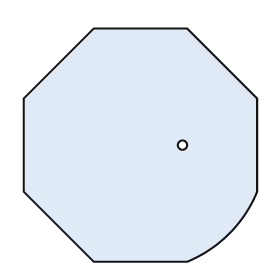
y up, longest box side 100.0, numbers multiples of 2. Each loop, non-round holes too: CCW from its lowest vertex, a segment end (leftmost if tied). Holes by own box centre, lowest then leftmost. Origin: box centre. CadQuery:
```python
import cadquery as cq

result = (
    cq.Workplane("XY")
    .moveTo(-20.0, -50.0)
    .lineTo(20.0, -50.0)
    .threePointArc((38.0, -38.0), (50.0, -20.0))
    .lineTo(50.0, 20.0)
    .lineTo(20.0, 50.0)
    .lineTo(-20.0, 50.0)
    .lineTo(-50.0, 20.0)
    .lineTo(-50.0, -20.0)
    .close()
    .moveTo(18.0, 0.0)
    .circle(2.0)
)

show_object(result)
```